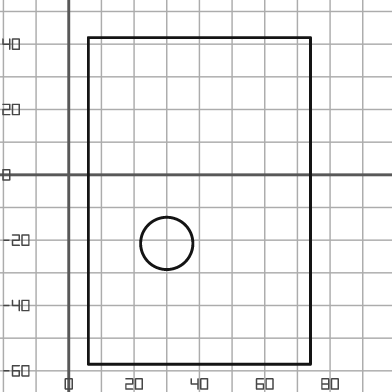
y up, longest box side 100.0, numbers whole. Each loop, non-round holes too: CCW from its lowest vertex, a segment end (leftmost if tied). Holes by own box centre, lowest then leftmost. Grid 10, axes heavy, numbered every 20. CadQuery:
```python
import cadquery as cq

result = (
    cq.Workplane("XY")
    .moveTo(6.0, -58.0)
    .lineTo(74.0, -58.0)
    .lineTo(74.0, 42.0)
    .lineTo(6.0, 42.0)
    .close()
    .moveTo(30.0, -21.0)
    .circle(8.0)
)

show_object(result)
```